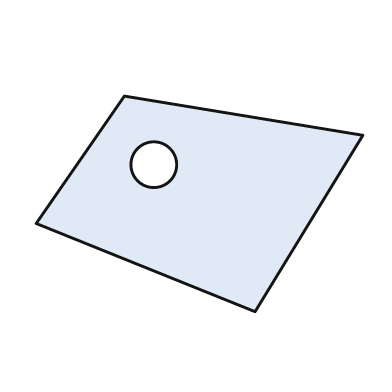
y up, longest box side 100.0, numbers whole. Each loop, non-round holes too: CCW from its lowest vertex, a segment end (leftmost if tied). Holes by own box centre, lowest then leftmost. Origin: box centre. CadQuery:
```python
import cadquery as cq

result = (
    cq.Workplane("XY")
    .moveTo(17.0, -33.0)
    .lineTo(50.0, 21.0)
    .lineTo(-23.0, 33.0)
    .lineTo(-50.0, -6.0)
    .close()
    .moveTo(-14.0, 12.0)
    .circle(7.0)
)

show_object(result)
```